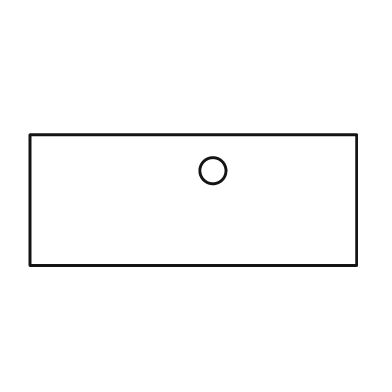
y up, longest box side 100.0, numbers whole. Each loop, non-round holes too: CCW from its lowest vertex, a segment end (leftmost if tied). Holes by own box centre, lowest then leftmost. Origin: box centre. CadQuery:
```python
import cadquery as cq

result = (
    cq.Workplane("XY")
    .moveTo(-50.0, -20.0)
    .lineTo(50.0, -20.0)
    .lineTo(50.0, 20.0)
    .lineTo(-50.0, 20.0)
    .close()
    .moveTo(6.0, 9.0)
    .circle(4.0)
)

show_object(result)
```